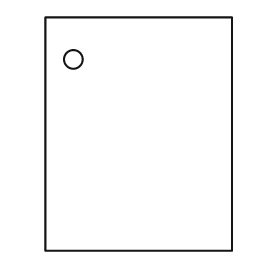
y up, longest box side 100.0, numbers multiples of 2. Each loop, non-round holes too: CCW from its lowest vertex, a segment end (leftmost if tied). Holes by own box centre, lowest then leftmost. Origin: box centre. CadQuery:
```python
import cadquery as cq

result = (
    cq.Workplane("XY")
    .moveTo(-40.0, -50.0)
    .lineTo(40.0, -50.0)
    .lineTo(40.0, 50.0)
    .lineTo(-40.0, 50.0)
    .close()
    .moveTo(-28.0, 32.0)
    .circle(4.0)
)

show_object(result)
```